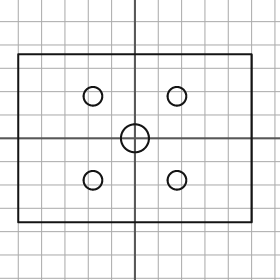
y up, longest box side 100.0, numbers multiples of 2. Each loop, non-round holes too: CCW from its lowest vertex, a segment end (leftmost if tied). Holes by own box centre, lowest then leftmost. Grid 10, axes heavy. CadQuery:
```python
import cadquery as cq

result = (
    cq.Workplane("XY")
    .moveTo(-50.0, -36.0)
    .lineTo(50.0, -36.0)
    .lineTo(50.0, 36.0)
    .lineTo(-50.0, 36.0)
    .close()
    .moveTo(-18.0, -18.0)
    .circle(4.0)
    .moveTo(18.0, -18.0)
    .circle(4.0)
    .moveTo(0.0, 0.0)
    .circle(6.0)
    .moveTo(-18.0, 18.0)
    .circle(4.0)
    .moveTo(18.0, 18.0)
    .circle(4.0)
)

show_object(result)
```